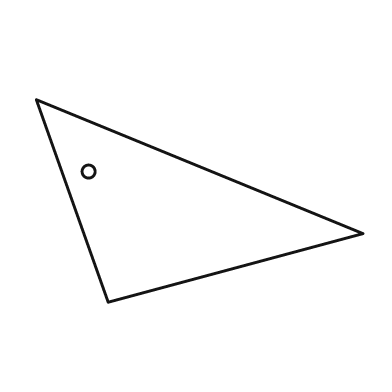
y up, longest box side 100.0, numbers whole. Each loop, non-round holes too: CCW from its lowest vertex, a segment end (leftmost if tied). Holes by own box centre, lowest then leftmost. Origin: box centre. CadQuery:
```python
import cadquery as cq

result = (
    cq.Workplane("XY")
    .moveTo(-28.0, -31.0)
    .lineTo(50.0, -10.0)
    .lineTo(-50.0, 31.0)
    .close()
    .moveTo(-34.0, 9.0)
    .circle(2.0)
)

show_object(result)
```